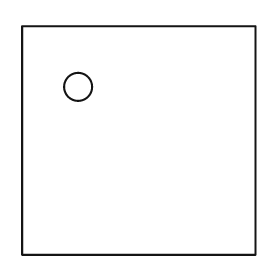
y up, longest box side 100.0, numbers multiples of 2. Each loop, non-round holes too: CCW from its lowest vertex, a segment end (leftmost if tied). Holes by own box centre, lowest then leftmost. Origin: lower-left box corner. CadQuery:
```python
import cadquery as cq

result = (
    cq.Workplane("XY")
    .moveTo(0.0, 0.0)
    .lineTo(100.0, 0.0)
    .lineTo(100.0, 98.0)
    .lineTo(0.0, 98.0)
    .close()
    .moveTo(24.0, 72.0)
    .circle(6.0)
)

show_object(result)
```